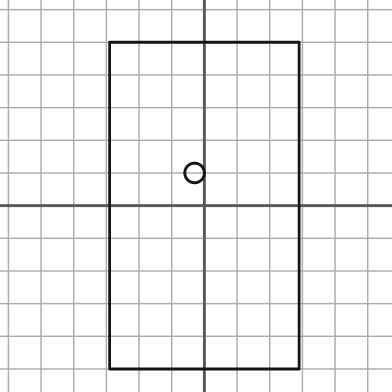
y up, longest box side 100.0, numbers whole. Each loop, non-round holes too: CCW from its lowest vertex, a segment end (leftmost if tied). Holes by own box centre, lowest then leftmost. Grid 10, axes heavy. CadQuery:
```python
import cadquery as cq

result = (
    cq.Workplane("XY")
    .moveTo(-29.0, -50.0)
    .lineTo(29.0, -50.0)
    .lineTo(29.0, 50.0)
    .lineTo(-29.0, 50.0)
    .close()
    .moveTo(-3.0, 10.0)
    .circle(3.0)
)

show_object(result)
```